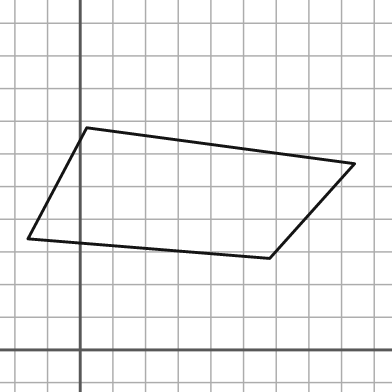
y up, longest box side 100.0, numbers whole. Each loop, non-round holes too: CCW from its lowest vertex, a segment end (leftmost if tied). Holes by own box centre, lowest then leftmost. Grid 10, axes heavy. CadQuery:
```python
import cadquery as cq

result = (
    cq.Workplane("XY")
    .moveTo(58.0, 28.0)
    .lineTo(84.0, 57.0)
    .lineTo(2.0, 68.0)
    .lineTo(-16.0, 34.0)
    .close()
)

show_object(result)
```